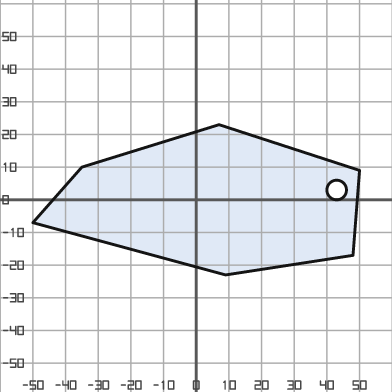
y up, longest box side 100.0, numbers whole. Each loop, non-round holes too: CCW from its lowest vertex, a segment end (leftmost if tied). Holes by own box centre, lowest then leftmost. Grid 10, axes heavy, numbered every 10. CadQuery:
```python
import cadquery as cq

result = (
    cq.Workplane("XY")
    .moveTo(9.0, -23.0)
    .lineTo(48.0, -17.0)
    .lineTo(50.0, 9.0)
    .lineTo(7.0, 23.0)
    .lineTo(-35.0, 10.0)
    .lineTo(-50.0, -7.0)
    .close()
    .moveTo(43.0, 3.0)
    .circle(3.0)
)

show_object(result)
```